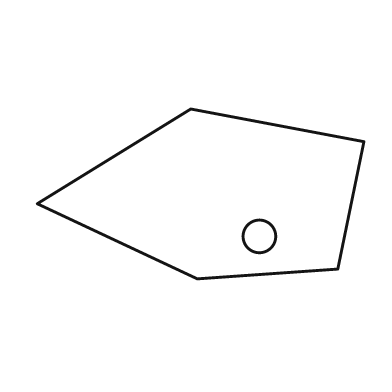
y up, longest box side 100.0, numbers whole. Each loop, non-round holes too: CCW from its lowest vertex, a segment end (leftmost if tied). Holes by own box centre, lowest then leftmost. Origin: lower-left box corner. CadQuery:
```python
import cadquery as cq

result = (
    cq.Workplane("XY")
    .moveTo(49.0, 0.0)
    .lineTo(92.0, 3.0)
    .lineTo(100.0, 42.0)
    .lineTo(47.0, 52.0)
    .lineTo(0.0, 23.0)
    .close()
    .moveTo(68.0, 13.0)
    .circle(5.0)
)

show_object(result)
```